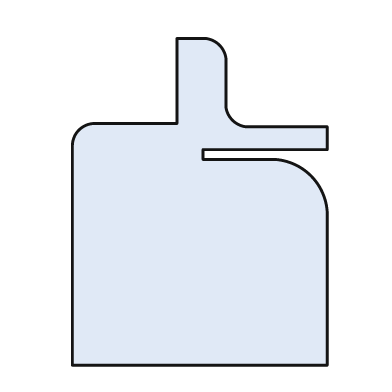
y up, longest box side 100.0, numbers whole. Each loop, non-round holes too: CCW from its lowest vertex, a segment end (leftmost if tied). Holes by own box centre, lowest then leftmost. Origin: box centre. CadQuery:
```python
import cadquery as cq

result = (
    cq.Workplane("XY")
    .moveTo(-39.0, -50.0)
    .lineTo(39.0, -50.0)
    .lineTo(39.0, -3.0)
    .threePointArc((34.0, 8.0), (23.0, 13.0))
    .lineTo(1.0, 13.0)
    .lineTo(1.0, 16.0)
    .lineTo(39.0, 16.0)
    .lineTo(39.0, 23.0)
    .lineTo(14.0, 23.0)
    .threePointArc((10.0, 25.0), (8.0, 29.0))
    .lineTo(8.0, 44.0)
    .threePointArc((6.0, 48.0), (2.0, 50.0))
    .lineTo(-7.0, 50.0)
    .lineTo(-7.0, 24.0)
    .lineTo(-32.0, 24.0)
    .threePointArc((-37.0, 22.0), (-39.0, 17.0))
    .close()
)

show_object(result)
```